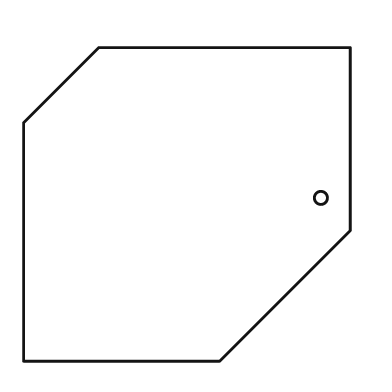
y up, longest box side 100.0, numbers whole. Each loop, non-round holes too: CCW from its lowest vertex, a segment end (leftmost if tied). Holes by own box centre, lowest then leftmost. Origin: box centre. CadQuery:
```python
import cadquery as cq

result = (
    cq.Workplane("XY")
    .moveTo(-50.0, -48.0)
    .lineTo(10.0, -48.0)
    .lineTo(50.0, -8.0)
    .lineTo(50.0, 48.0)
    .lineTo(-27.0, 48.0)
    .lineTo(-50.0, 25.0)
    .close()
    .moveTo(41.0, 2.0)
    .circle(2.0)
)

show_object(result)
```